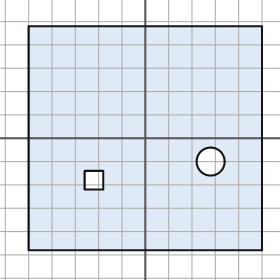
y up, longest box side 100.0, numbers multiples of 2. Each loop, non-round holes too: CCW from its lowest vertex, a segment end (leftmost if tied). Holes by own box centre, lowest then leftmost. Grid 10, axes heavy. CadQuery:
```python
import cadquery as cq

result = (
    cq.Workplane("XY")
    .moveTo(-50.0, -48.0)
    .lineTo(50.0, -48.0)
    .lineTo(50.0, 48.0)
    .lineTo(-50.0, 48.0)
    .close()
    .moveTo(-26.0, -22.0)
    .lineTo(-18.0, -22.0)
    .lineTo(-18.0, -14.0)
    .lineTo(-26.0, -14.0)
    .close()
    .moveTo(28.0, -10.0)
    .circle(6.0)
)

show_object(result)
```